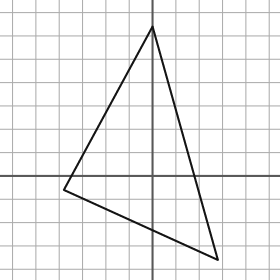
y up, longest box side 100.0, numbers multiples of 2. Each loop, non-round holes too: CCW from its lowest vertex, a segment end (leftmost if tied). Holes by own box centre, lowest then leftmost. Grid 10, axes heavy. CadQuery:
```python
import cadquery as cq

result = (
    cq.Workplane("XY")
    .moveTo(28.0, -36.0)
    .lineTo(0.0, 64.0)
    .lineTo(-38.0, -6.0)
    .close()
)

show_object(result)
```